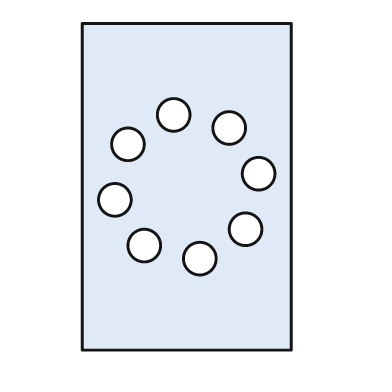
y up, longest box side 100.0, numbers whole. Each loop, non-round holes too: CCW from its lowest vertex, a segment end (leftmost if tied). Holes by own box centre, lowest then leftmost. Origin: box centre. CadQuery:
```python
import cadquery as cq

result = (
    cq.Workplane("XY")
    .moveTo(-32.0, -50.0)
    .lineTo(32.0, -50.0)
    .lineTo(32.0, 50.0)
    .lineTo(-32.0, 50.0)
    .close()
    .moveTo(4.0, -22.0)
    .circle(5.0)
    .moveTo(-13.0, -18.0)
    .circle(5.0)
    .moveTo(18.0, -13.0)
    .circle(5.0)
    .moveTo(-22.0, -4.0)
    .circle(5.0)
    .moveTo(22.0, 4.0)
    .circle(5.0)
    .moveTo(-18.0, 13.0)
    .circle(5.0)
    .moveTo(13.0, 18.0)
    .circle(5.0)
    .moveTo(-4.0, 22.0)
    .circle(5.0)
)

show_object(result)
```